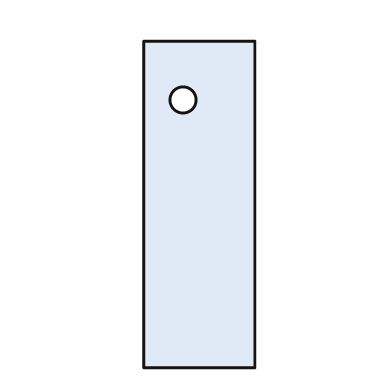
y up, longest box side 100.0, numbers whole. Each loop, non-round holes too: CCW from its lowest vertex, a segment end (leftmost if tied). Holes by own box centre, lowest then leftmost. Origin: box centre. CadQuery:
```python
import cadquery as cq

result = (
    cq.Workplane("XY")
    .moveTo(-17.0, -50.0)
    .lineTo(17.0, -50.0)
    .lineTo(17.0, 50.0)
    .lineTo(-17.0, 50.0)
    .close()
    .moveTo(-5.0, 32.0)
    .circle(4.0)
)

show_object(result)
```